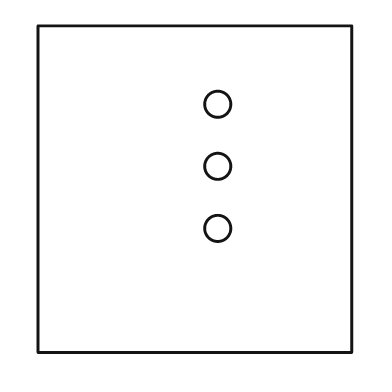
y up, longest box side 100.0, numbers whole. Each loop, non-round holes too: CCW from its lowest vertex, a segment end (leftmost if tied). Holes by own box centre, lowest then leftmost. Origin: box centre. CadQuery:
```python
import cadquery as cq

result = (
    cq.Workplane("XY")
    .moveTo(-48.0, -50.0)
    .lineTo(48.0, -50.0)
    .lineTo(48.0, 50.0)
    .lineTo(-48.0, 50.0)
    .close()
    .moveTo(7.0, -12.0)
    .circle(4.0)
    .moveTo(7.0, 7.0)
    .circle(4.0)
    .moveTo(7.0, 26.0)
    .circle(4.0)
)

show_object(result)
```